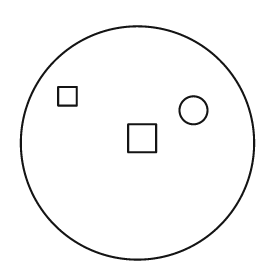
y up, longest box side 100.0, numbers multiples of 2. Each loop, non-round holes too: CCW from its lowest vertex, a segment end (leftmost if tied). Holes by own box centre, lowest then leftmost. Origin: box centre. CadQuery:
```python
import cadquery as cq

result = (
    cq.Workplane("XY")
    .moveTo(0.0, 0.0)
    .circle(50.0)
    .moveTo(-4.0, -4.0)
    .lineTo(8.0, -4.0)
    .lineTo(8.0, 8.0)
    .lineTo(-4.0, 8.0)
    .close()
    .moveTo(24.0, 14.0)
    .circle(6.0)
    .moveTo(-34.0, 16.0)
    .lineTo(-26.0, 16.0)
    .lineTo(-26.0, 24.0)
    .lineTo(-34.0, 24.0)
    .close()
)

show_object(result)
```